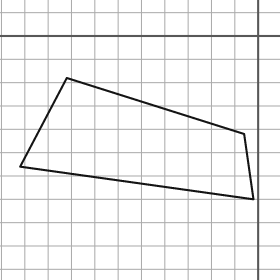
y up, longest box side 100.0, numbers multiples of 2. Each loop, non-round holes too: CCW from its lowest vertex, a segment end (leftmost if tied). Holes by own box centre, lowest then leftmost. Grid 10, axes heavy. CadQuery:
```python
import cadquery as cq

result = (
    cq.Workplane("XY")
    .moveTo(-2.0, -70.0)
    .lineTo(-6.0, -42.0)
    .lineTo(-82.0, -18.0)
    .lineTo(-102.0, -56.0)
    .close()
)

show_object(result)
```